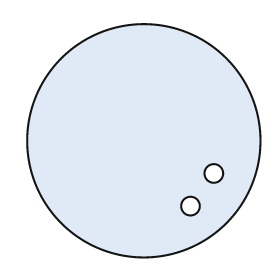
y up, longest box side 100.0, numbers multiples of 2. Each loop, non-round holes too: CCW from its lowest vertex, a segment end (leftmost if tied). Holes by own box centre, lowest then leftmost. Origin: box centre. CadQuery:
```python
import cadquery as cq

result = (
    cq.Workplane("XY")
    .moveTo(0.0, 0.0)
    .circle(50.0)
    .moveTo(20.0, -28.0)
    .circle(4.0)
    .moveTo(30.0, -14.0)
    .circle(4.0)
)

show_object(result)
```